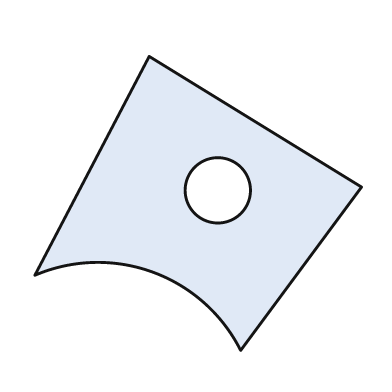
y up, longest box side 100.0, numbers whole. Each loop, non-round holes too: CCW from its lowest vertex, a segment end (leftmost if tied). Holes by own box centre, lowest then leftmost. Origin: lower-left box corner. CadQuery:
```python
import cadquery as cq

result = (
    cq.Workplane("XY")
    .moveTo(63.0, 0.0)
    .lineTo(100.0, 50.0)
    .lineTo(35.0, 90.0)
    .lineTo(0.0, 23.0)
    .threePointArc((36.0, 24.0), (63.0, 0.0))
    .close()
    .moveTo(56.0, 49.0)
    .circle(10.0)
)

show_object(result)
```